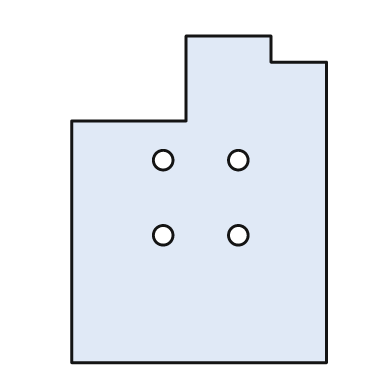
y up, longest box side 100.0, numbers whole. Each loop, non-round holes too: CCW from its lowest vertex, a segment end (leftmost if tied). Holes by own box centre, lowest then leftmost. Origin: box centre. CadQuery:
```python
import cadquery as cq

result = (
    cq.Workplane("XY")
    .moveTo(-39.0, -50.0)
    .lineTo(39.0, -50.0)
    .lineTo(39.0, 42.0)
    .lineTo(22.0, 42.0)
    .lineTo(22.0, 50.0)
    .lineTo(-4.0, 50.0)
    .lineTo(-4.0, 24.0)
    .lineTo(-39.0, 24.0)
    .close()
    .moveTo(-11.0, -11.0)
    .circle(3.0)
    .moveTo(12.0, -11.0)
    .circle(3.0)
    .moveTo(-11.0, 12.0)
    .circle(3.0)
    .moveTo(12.0, 12.0)
    .circle(3.0)
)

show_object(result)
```